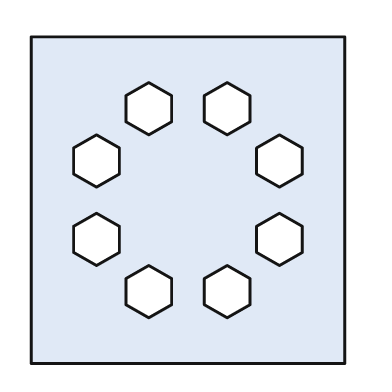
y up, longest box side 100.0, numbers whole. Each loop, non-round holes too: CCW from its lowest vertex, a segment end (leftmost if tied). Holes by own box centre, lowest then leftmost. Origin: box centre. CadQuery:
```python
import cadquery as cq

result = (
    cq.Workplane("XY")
    .moveTo(-48.0, -50.0)
    .lineTo(48.0, -50.0)
    .lineTo(48.0, 50.0)
    .lineTo(-48.0, 50.0)
    .close()
    .moveTo(-12.0, -36.0)
    .lineTo(-5.0, -32.0)
    .lineTo(-5.0, -24.0)
    .lineTo(-12.0, -20.0)
    .lineTo(-19.0, -24.0)
    .lineTo(-19.0, -32.0)
    .close()
    .moveTo(12.0, -36.0)
    .lineTo(19.0, -32.0)
    .lineTo(19.0, -24.0)
    .lineTo(12.0, -20.0)
    .lineTo(5.0, -24.0)
    .lineTo(5.0, -32.0)
    .close()
    .moveTo(-28.0, -20.0)
    .lineTo(-21.0, -16.0)
    .lineTo(-21.0, -8.0)
    .lineTo(-28.0, -4.0)
    .lineTo(-35.0, -8.0)
    .lineTo(-35.0, -16.0)
    .close()
    .moveTo(28.0, -20.0)
    .lineTo(35.0, -16.0)
    .lineTo(35.0, -8.0)
    .lineTo(28.0, -4.0)
    .lineTo(21.0, -8.0)
    .lineTo(21.0, -16.0)
    .close()
    .moveTo(-28.0, 4.0)
    .lineTo(-21.0, 8.0)
    .lineTo(-21.0, 16.0)
    .lineTo(-28.0, 20.0)
    .lineTo(-35.0, 16.0)
    .lineTo(-35.0, 8.0)
    .close()
    .moveTo(28.0, 4.0)
    .lineTo(35.0, 8.0)
    .lineTo(35.0, 16.0)
    .lineTo(28.0, 20.0)
    .lineTo(21.0, 16.0)
    .lineTo(21.0, 8.0)
    .close()
    .moveTo(-12.0, 20.0)
    .lineTo(-5.0, 24.0)
    .lineTo(-5.0, 32.0)
    .lineTo(-12.0, 36.0)
    .lineTo(-19.0, 32.0)
    .lineTo(-19.0, 24.0)
    .close()
    .moveTo(12.0, 20.0)
    .lineTo(19.0, 24.0)
    .lineTo(19.0, 32.0)
    .lineTo(12.0, 36.0)
    .lineTo(5.0, 32.0)
    .lineTo(5.0, 24.0)
    .close()
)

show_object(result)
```